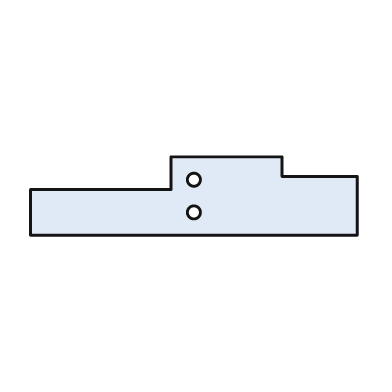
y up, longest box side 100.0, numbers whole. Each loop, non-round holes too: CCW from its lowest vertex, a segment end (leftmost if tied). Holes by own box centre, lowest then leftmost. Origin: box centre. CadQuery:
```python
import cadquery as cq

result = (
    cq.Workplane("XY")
    .moveTo(-50.0, -12.0)
    .lineTo(50.0, -12.0)
    .lineTo(50.0, 6.0)
    .lineTo(27.0, 6.0)
    .lineTo(27.0, 12.0)
    .lineTo(-7.0, 12.0)
    .lineTo(-7.0, 2.0)
    .lineTo(-50.0, 2.0)
    .close()
    .moveTo(0.0, -5.0)
    .circle(2.0)
    .moveTo(0.0, 5.0)
    .circle(2.0)
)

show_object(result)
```